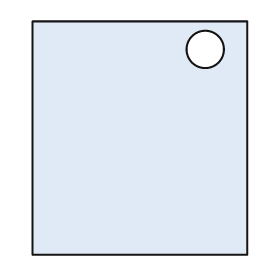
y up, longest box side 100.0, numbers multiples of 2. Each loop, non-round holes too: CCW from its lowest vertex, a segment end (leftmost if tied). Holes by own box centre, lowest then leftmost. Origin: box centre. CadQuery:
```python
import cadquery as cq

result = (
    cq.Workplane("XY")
    .moveTo(-46.0, -50.0)
    .lineTo(46.0, -50.0)
    .lineTo(46.0, 50.0)
    .lineTo(-46.0, 50.0)
    .close()
    .moveTo(28.0, 38.0)
    .circle(8.0)
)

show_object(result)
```